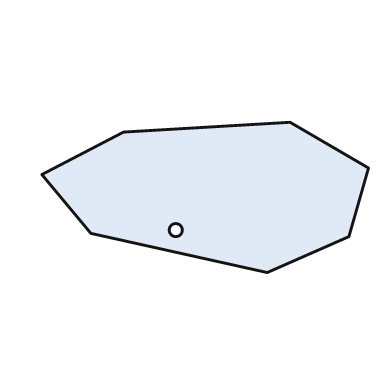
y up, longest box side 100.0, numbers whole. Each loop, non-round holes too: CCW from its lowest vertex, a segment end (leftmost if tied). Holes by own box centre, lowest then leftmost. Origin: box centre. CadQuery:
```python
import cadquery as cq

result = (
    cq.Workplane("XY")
    .moveTo(19.0, -23.0)
    .lineTo(44.0, -12.0)
    .lineTo(50.0, 9.0)
    .lineTo(26.0, 23.0)
    .lineTo(-25.0, 20.0)
    .lineTo(-50.0, 7.0)
    .lineTo(-35.0, -11.0)
    .close()
    .moveTo(-9.0, -10.0)
    .circle(2.0)
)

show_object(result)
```